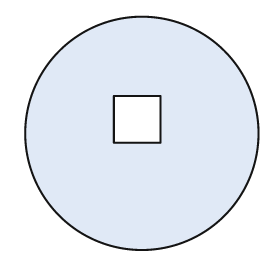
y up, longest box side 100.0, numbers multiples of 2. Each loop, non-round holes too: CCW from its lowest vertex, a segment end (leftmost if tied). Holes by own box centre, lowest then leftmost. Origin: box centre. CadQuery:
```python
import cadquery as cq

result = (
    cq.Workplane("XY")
    .moveTo(0.0, 0.0)
    .circle(50.0)
    .moveTo(-12.0, -4.0)
    .lineTo(8.0, -4.0)
    .lineTo(8.0, 16.0)
    .lineTo(-12.0, 16.0)
    .close()
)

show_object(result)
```